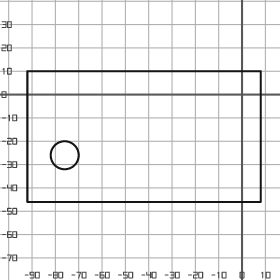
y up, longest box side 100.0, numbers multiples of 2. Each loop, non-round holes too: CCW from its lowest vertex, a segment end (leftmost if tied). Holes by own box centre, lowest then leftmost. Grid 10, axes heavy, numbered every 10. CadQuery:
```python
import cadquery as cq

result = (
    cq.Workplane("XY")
    .moveTo(-92.0, -46.0)
    .lineTo(8.0, -46.0)
    .lineTo(8.0, 10.0)
    .lineTo(-92.0, 10.0)
    .close()
    .moveTo(-76.0, -26.0)
    .circle(6.0)
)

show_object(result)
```